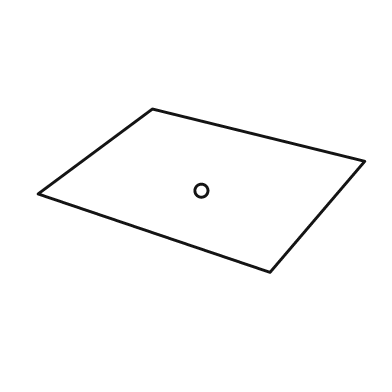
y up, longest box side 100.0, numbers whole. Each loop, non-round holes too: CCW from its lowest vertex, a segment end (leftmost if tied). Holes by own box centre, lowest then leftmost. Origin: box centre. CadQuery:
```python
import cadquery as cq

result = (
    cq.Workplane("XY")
    .moveTo(21.0, -25.0)
    .lineTo(50.0, 9.0)
    .lineTo(-15.0, 25.0)
    .lineTo(-50.0, -1.0)
    .close()
    .moveTo(0.0, 0.0)
    .circle(2.0)
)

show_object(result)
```